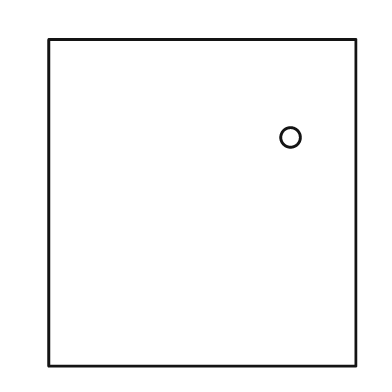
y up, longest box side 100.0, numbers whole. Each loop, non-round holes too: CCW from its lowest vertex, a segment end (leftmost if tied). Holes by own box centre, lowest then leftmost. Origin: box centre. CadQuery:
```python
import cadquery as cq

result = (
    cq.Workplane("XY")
    .moveTo(-47.0, -50.0)
    .lineTo(47.0, -50.0)
    .lineTo(47.0, 50.0)
    .lineTo(-47.0, 50.0)
    .close()
    .moveTo(27.0, 20.0)
    .circle(3.0)
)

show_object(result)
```